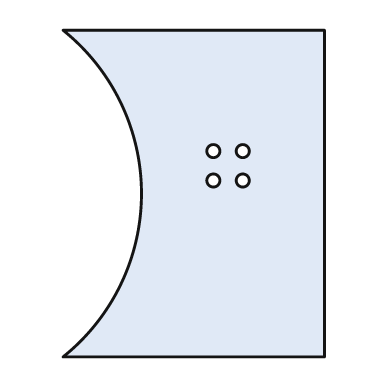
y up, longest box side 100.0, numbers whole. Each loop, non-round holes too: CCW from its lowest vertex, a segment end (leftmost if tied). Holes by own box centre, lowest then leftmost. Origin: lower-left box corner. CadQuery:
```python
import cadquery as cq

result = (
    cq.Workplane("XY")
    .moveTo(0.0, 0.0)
    .lineTo(80.0, 0.0)
    .lineTo(80.0, 100.0)
    .lineTo(0.0, 100.0)
    .threePointArc((24.0, 50.0), (0.0, 0.0))
    .close()
    .moveTo(46.0, 54.0)
    .circle(2.0)
    .moveTo(55.0, 54.0)
    .circle(2.0)
    .moveTo(46.0, 63.0)
    .circle(2.0)
    .moveTo(55.0, 63.0)
    .circle(2.0)
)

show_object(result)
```